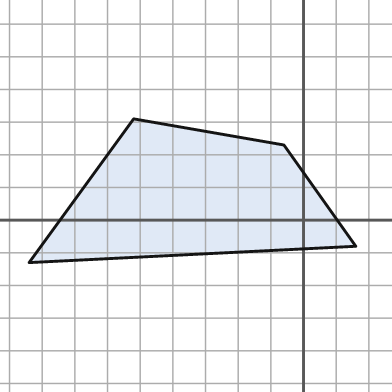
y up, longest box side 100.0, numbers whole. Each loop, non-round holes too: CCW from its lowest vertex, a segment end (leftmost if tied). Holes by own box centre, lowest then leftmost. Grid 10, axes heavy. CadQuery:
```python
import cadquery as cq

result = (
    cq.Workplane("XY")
    .moveTo(-84.0, -13.0)
    .lineTo(16.0, -8.0)
    .lineTo(-6.0, 23.0)
    .lineTo(-52.0, 31.0)
    .close()
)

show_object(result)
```